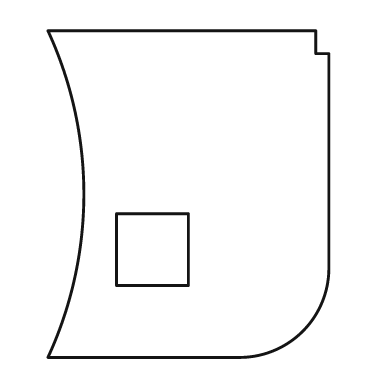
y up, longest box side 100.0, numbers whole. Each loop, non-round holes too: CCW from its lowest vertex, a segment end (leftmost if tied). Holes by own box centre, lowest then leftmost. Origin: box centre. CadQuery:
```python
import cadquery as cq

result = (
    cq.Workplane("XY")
    .moveTo(-43.0, -50.0)
    .lineTo(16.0, -50.0)
    .threePointArc((35.0, -42.0), (43.0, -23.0))
    .lineTo(43.0, 43.0)
    .lineTo(39.0, 43.0)
    .lineTo(39.0, 50.0)
    .lineTo(-43.0, 50.0)
    .threePointArc((-32.0, 0.0), (-43.0, -50.0))
    .close()
    .moveTo(-22.0, -28.0)
    .lineTo(0.0, -28.0)
    .lineTo(0.0, -6.0)
    .lineTo(-22.0, -6.0)
    .close()
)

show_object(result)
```